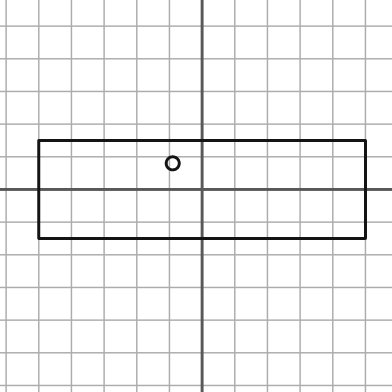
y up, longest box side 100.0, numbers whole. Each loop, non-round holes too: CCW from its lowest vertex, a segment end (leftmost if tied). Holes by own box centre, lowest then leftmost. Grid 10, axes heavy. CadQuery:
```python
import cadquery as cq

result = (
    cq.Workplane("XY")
    .moveTo(-50.0, -15.0)
    .lineTo(50.0, -15.0)
    .lineTo(50.0, 15.0)
    .lineTo(-50.0, 15.0)
    .close()
    .moveTo(-9.0, 8.0)
    .circle(2.0)
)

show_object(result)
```